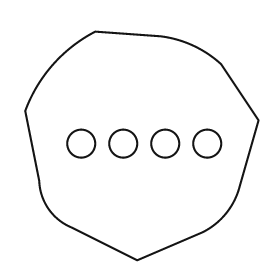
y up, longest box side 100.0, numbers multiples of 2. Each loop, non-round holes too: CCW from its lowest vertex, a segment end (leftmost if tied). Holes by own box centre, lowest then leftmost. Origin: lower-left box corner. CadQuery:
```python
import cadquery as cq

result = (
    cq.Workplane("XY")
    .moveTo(48.0, 0.0)
    .lineTo(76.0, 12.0)
    .threePointArc((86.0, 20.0), (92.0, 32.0))
    .lineTo(100.0, 60.0)
    .lineTo(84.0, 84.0)
    .threePointArc((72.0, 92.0), (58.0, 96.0))
    .lineTo(30.0, 98.0)
    .threePointArc((12.0, 84.0), (0.0, 64.0))
    .lineTo(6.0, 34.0)
    .threePointArc((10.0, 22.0), (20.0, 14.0))
    .close()
    .moveTo(24.0, 50.0)
    .circle(6.0)
    .moveTo(42.0, 50.0)
    .circle(6.0)
    .moveTo(60.0, 50.0)
    .circle(6.0)
    .moveTo(78.0, 50.0)
    .circle(6.0)
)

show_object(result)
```